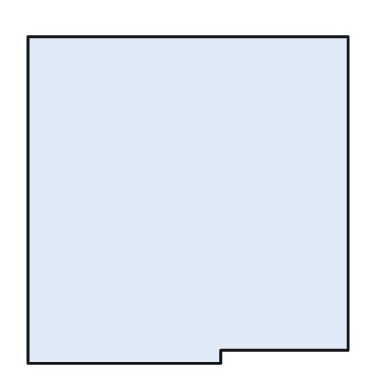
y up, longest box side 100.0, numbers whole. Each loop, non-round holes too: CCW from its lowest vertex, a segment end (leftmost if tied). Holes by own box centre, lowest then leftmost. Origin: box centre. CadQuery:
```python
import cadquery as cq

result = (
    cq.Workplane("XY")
    .moveTo(-49.0, -50.0)
    .lineTo(10.0, -50.0)
    .lineTo(10.0, -46.0)
    .lineTo(49.0, -46.0)
    .lineTo(49.0, 50.0)
    .lineTo(-49.0, 50.0)
    .close()
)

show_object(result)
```